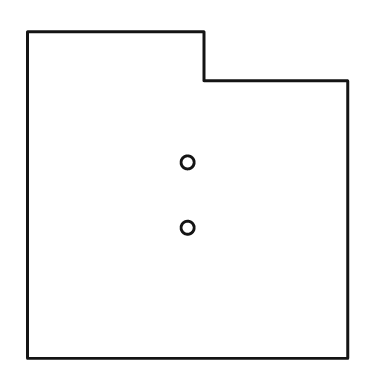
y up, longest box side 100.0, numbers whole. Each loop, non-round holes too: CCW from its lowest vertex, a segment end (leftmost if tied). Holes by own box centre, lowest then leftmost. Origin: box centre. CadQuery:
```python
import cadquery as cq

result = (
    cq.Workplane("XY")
    .moveTo(-49.0, -50.0)
    .lineTo(49.0, -50.0)
    .lineTo(49.0, 35.0)
    .lineTo(5.0, 35.0)
    .lineTo(5.0, 50.0)
    .lineTo(-49.0, 50.0)
    .close()
    .moveTo(0.0, -10.0)
    .circle(2.0)
    .moveTo(0.0, 10.0)
    .circle(2.0)
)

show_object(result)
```